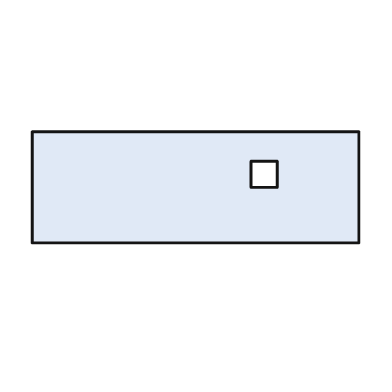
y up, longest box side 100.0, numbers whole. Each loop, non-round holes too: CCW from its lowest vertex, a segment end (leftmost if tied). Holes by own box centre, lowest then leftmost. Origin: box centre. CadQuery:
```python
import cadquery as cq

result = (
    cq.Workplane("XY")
    .moveTo(-50.0, -17.0)
    .lineTo(50.0, -17.0)
    .lineTo(50.0, 17.0)
    .lineTo(-50.0, 17.0)
    .close()
    .moveTo(17.0, 0.0)
    .lineTo(25.0, 0.0)
    .lineTo(25.0, 8.0)
    .lineTo(17.0, 8.0)
    .close()
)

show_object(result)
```